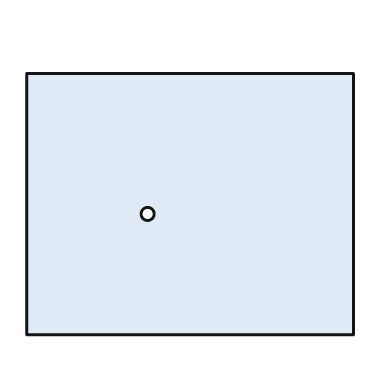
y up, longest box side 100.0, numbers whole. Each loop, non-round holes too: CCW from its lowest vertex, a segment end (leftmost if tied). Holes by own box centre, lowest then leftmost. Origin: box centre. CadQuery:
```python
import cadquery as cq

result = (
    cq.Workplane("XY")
    .moveTo(-50.0, -40.0)
    .lineTo(50.0, -40.0)
    .lineTo(50.0, 40.0)
    .lineTo(-50.0, 40.0)
    .close()
    .moveTo(-13.0, -3.0)
    .circle(2.0)
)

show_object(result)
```